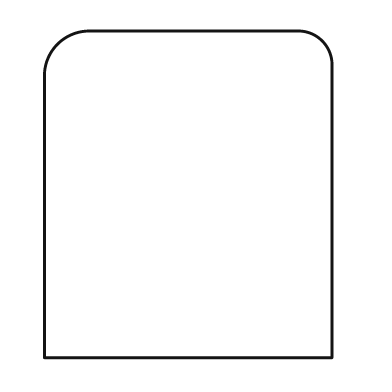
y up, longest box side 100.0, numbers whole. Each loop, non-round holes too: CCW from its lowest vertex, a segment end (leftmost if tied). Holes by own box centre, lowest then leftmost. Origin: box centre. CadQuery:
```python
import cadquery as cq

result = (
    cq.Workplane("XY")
    .moveTo(-44.0, -50.0)
    .lineTo(44.0, -50.0)
    .lineTo(44.0, 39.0)
    .threePointArc((41.0, 47.0), (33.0, 50.0))
    .lineTo(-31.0, 50.0)
    .threePointArc((-40.0, 46.0), (-44.0, 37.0))
    .close()
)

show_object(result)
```